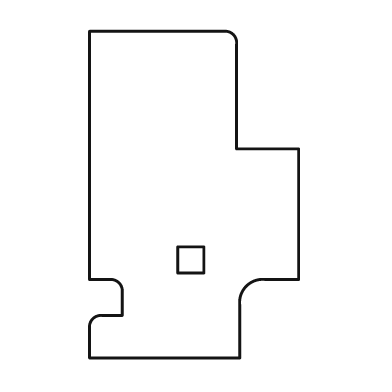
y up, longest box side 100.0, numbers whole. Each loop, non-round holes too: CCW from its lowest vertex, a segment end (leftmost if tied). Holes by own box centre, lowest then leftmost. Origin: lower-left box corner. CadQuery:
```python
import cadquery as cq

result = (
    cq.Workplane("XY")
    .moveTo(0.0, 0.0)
    .lineTo(46.0, 0.0)
    .lineTo(46.0, 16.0)
    .threePointArc((48.0, 22.0), (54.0, 24.0))
    .lineTo(64.0, 24.0)
    .lineTo(64.0, 64.0)
    .lineTo(45.0, 64.0)
    .lineTo(45.0, 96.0)
    .threePointArc((44.0, 99.0), (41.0, 100.0))
    .lineTo(0.0, 100.0)
    .lineTo(0.0, 24.0)
    .lineTo(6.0, 24.0)
    .threePointArc((9.0, 23.0), (10.0, 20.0))
    .lineTo(10.0, 13.0)
    .lineTo(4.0, 13.0)
    .threePointArc((1.0, 12.0), (0.0, 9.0))
    .close()
    .moveTo(27.0, 26.0)
    .lineTo(35.0, 26.0)
    .lineTo(35.0, 34.0)
    .lineTo(27.0, 34.0)
    .close()
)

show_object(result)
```